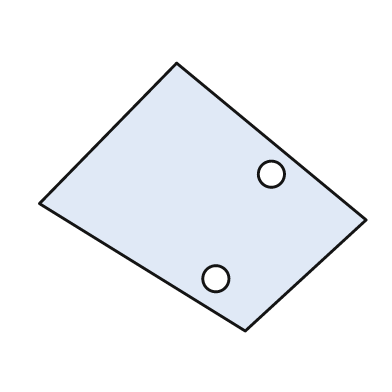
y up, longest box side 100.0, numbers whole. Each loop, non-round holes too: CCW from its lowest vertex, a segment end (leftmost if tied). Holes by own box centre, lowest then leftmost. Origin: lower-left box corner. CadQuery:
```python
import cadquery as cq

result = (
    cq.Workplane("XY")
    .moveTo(63.0, 0.0)
    .lineTo(100.0, 34.0)
    .lineTo(42.0, 82.0)
    .lineTo(0.0, 39.0)
    .close()
    .moveTo(54.0, 16.0)
    .circle(4.0)
    .moveTo(71.0, 48.0)
    .circle(4.0)
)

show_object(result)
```